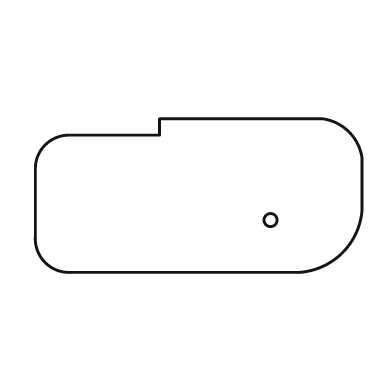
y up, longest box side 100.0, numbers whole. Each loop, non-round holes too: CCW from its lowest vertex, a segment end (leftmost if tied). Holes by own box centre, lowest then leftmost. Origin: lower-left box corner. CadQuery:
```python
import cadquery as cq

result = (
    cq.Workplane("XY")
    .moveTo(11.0, 0.0)
    .lineTo(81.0, 0.0)
    .threePointArc((94.0, 6.0), (100.0, 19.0))
    .lineTo(100.0, 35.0)
    .threePointArc((96.0, 43.0), (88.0, 47.0))
    .lineTo(38.0, 47.0)
    .lineTo(38.0, 42.0)
    .lineTo(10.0, 42.0)
    .threePointArc((3.0, 39.0), (0.0, 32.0))
    .lineTo(0.0, 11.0)
    .threePointArc((3.0, 3.0), (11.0, 0.0))
    .close()
    .moveTo(72.0, 16.0)
    .circle(2.0)
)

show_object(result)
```